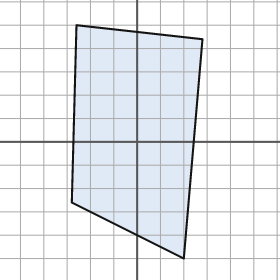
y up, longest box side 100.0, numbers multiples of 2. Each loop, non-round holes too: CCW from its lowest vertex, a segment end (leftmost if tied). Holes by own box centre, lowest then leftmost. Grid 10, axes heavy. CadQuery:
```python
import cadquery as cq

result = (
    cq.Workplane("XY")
    .moveTo(20.0, -50.0)
    .lineTo(28.0, 44.0)
    .lineTo(-26.0, 50.0)
    .lineTo(-28.0, -26.0)
    .close()
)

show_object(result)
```